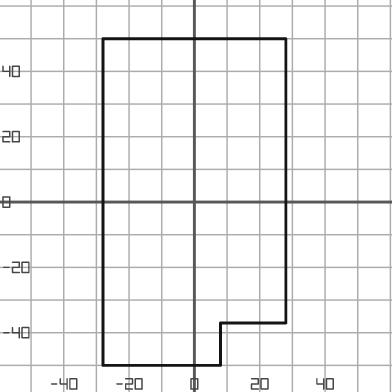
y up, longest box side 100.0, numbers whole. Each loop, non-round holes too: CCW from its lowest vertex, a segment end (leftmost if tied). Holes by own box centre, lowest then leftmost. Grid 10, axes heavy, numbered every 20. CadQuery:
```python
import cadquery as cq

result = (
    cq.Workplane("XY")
    .moveTo(-28.0, -50.0)
    .lineTo(8.0, -50.0)
    .lineTo(8.0, -37.0)
    .lineTo(28.0, -37.0)
    .lineTo(28.0, 50.0)
    .lineTo(-28.0, 50.0)
    .close()
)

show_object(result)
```